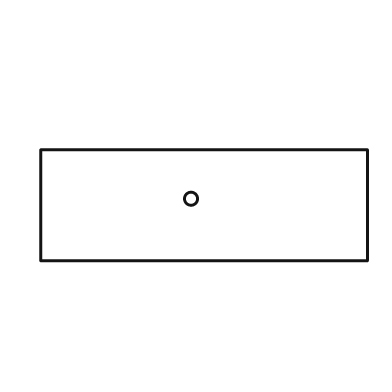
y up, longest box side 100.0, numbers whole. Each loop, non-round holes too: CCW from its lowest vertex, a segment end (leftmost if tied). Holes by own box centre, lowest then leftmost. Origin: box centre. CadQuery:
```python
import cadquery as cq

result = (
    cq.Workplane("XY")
    .moveTo(-50.0, -17.0)
    .lineTo(50.0, -17.0)
    .lineTo(50.0, 17.0)
    .lineTo(-50.0, 17.0)
    .close()
    .moveTo(-4.0, 2.0)
    .circle(2.0)
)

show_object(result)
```